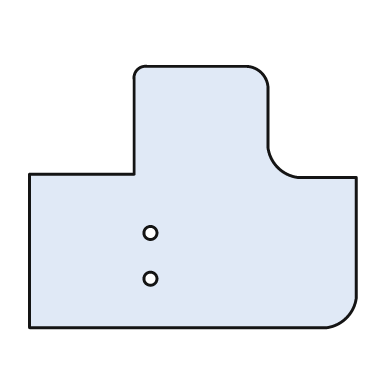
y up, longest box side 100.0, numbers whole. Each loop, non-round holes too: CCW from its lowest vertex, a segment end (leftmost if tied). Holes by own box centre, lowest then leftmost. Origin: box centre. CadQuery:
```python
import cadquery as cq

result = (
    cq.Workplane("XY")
    .moveTo(-50.0, -40.0)
    .lineTo(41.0, -40.0)
    .threePointArc((47.0, -37.0), (50.0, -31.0))
    .lineTo(50.0, 6.0)
    .lineTo(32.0, 6.0)
    .threePointArc((26.0, 9.0), (23.0, 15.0))
    .lineTo(23.0, 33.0)
    .threePointArc((21.0, 38.0), (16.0, 40.0))
    .lineTo(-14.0, 40.0)
    .threePointArc((-17.0, 39.0), (-18.0, 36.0))
    .lineTo(-18.0, 7.0)
    .lineTo(-50.0, 7.0)
    .close()
    .moveTo(-13.0, -25.0)
    .circle(2.0)
    .moveTo(-13.0, -11.0)
    .circle(2.0)
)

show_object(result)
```